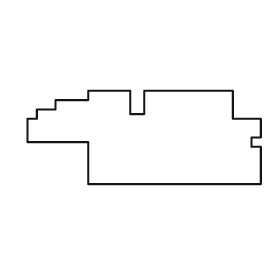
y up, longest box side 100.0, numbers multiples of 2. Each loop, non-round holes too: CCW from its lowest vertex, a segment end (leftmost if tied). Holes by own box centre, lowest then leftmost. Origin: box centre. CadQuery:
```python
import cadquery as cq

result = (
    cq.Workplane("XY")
    .moveTo(-24.0, -20.0)
    .lineTo(50.0, -20.0)
    .lineTo(50.0, -4.0)
    .lineTo(46.0, -4.0)
    .lineTo(46.0, 0.0)
    .lineTo(50.0, 0.0)
    .lineTo(50.0, 8.0)
    .lineTo(38.0, 8.0)
    .lineTo(38.0, 20.0)
    .lineTo(0.0, 20.0)
    .lineTo(0.0, 10.0)
    .lineTo(-6.0, 10.0)
    .lineTo(-6.0, 20.0)
    .lineTo(-24.0, 20.0)
    .lineTo(-24.0, 16.0)
    .lineTo(-38.0, 16.0)
    .lineTo(-38.0, 12.0)
    .lineTo(-46.0, 12.0)
    .lineTo(-46.0, 8.0)
    .lineTo(-50.0, 8.0)
    .lineTo(-50.0, -2.0)
    .lineTo(-24.0, -2.0)
    .close()
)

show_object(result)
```